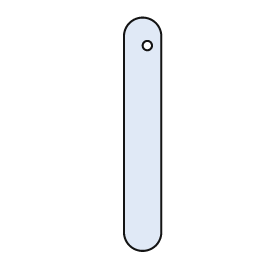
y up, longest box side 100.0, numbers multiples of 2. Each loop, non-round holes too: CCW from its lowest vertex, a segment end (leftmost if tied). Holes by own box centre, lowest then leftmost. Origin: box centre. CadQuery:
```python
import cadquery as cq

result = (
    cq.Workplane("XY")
    .moveTo(-8.0, -42.0)
    .threePointArc((0.0, -50.0), (8.0, -42.0))
    .lineTo(8.0, 42.0)
    .threePointArc((0.0, 50.0), (-8.0, 42.0))
    .close()
    .moveTo(2.0, 38.0)
    .circle(2.0)
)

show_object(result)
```